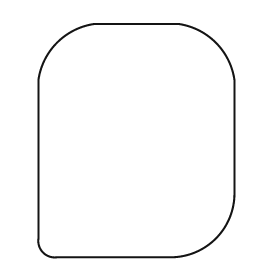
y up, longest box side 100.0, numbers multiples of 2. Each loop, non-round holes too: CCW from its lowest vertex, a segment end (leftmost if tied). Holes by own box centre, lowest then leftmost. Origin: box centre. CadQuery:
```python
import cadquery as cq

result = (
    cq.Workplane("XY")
    .moveTo(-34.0, -50.0)
    .lineTo(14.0, -50.0)
    .threePointArc((34.0, -42.0), (42.0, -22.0))
    .lineTo(42.0, 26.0)
    .threePointArc((34.0, 42.0), (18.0, 50.0))
    .lineTo(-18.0, 50.0)
    .threePointArc((-34.0, 42.0), (-42.0, 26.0))
    .lineTo(-42.0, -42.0)
    .threePointArc((-40.0, -48.0), (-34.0, -50.0))
    .close()
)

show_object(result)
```